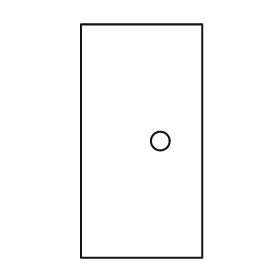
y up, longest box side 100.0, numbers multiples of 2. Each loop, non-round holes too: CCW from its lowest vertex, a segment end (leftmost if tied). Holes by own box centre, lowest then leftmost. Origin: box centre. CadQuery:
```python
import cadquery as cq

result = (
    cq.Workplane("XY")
    .moveTo(-26.0, -50.0)
    .lineTo(26.0, -50.0)
    .lineTo(26.0, 50.0)
    .lineTo(-26.0, 50.0)
    .close()
    .moveTo(8.0, 0.0)
    .circle(4.0)
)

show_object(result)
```